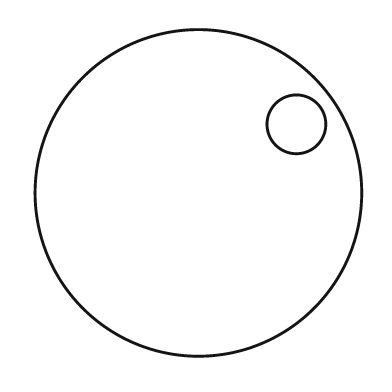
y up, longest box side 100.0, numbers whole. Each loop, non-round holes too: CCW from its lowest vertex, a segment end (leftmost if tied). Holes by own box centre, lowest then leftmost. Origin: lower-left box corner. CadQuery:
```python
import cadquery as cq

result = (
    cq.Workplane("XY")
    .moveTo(50.0, 50.0)
    .circle(50.0)
    .moveTo(80.0, 71.0)
    .circle(9.0)
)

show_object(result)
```